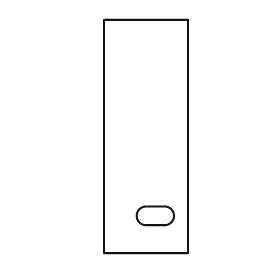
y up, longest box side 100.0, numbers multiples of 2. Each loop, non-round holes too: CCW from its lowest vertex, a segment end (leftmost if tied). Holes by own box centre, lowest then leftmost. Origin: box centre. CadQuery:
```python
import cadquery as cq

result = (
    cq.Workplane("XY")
    .moveTo(-18.0, -50.0)
    .lineTo(18.0, -50.0)
    .lineTo(18.0, 50.0)
    .lineTo(-18.0, 50.0)
    .close()
    .moveTo(0.0, -38.0)
    .lineTo(8.0, -38.0)
    .threePointArc((12.0, -34.0), (8.0, -30.0))
    .lineTo(0.0, -30.0)
    .threePointArc((-4.0, -34.0), (0.0, -38.0))
    .close()
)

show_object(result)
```